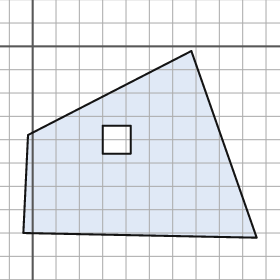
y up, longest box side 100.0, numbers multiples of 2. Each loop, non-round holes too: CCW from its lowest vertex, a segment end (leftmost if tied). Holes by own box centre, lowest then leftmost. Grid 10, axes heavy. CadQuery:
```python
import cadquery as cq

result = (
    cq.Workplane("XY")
    .moveTo(96.0, -82.0)
    .lineTo(68.0, -2.0)
    .lineTo(-2.0, -38.0)
    .lineTo(-4.0, -80.0)
    .close()
    .moveTo(30.0, -46.0)
    .lineTo(42.0, -46.0)
    .lineTo(42.0, -34.0)
    .lineTo(30.0, -34.0)
    .close()
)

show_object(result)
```